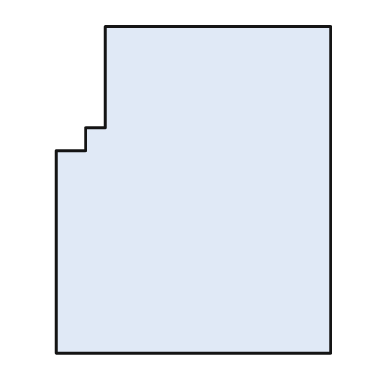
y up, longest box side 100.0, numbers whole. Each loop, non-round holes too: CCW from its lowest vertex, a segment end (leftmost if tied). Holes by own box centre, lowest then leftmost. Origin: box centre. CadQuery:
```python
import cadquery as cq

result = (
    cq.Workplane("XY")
    .moveTo(-42.0, -50.0)
    .lineTo(42.0, -50.0)
    .lineTo(42.0, 50.0)
    .lineTo(-27.0, 50.0)
    .lineTo(-27.0, 19.0)
    .lineTo(-33.0, 19.0)
    .lineTo(-33.0, 12.0)
    .lineTo(-42.0, 12.0)
    .close()
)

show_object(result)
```